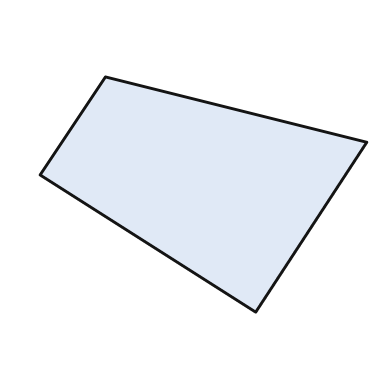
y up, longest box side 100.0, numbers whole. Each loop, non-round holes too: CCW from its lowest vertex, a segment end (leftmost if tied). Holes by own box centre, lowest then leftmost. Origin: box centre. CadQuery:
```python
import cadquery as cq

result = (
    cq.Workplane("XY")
    .moveTo(16.0, -36.0)
    .lineTo(50.0, 16.0)
    .lineTo(-30.0, 36.0)
    .lineTo(-50.0, 6.0)
    .close()
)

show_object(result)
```